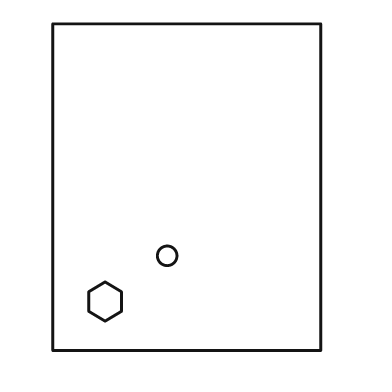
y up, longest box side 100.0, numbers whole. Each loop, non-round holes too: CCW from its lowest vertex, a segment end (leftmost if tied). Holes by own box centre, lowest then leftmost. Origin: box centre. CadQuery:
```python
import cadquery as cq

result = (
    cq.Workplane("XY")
    .moveTo(-41.0, -50.0)
    .lineTo(41.0, -50.0)
    .lineTo(41.0, 50.0)
    .lineTo(-41.0, 50.0)
    .close()
    .moveTo(-25.0, -41.0)
    .lineTo(-20.0, -38.0)
    .lineTo(-20.0, -32.0)
    .lineTo(-25.0, -29.0)
    .lineTo(-30.0, -32.0)
    .lineTo(-30.0, -38.0)
    .close()
    .moveTo(-6.0, -21.0)
    .circle(3.0)
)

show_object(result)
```